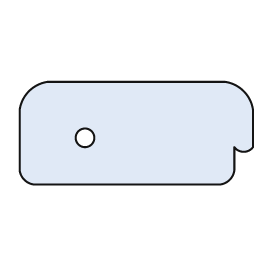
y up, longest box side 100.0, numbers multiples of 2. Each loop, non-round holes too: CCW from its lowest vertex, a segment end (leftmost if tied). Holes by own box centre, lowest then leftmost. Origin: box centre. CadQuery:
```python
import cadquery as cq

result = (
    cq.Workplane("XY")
    .moveTo(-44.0, -22.0)
    .lineTo(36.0, -22.0)
    .threePointArc((40.0, -20.0), (42.0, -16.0))
    .lineTo(42.0, -6.0)
    .threePointArc((46.0, -8.0), (50.0, -6.0))
    .lineTo(50.0, 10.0)
    .threePointArc((46.0, 18.0), (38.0, 22.0))
    .lineTo(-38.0, 22.0)
    .threePointArc((-46.0, 18.0), (-50.0, 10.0))
    .lineTo(-50.0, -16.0)
    .threePointArc((-48.0, -20.0), (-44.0, -22.0))
    .close()
    .moveTo(-22.0, -2.0)
    .circle(4.0)
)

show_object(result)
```